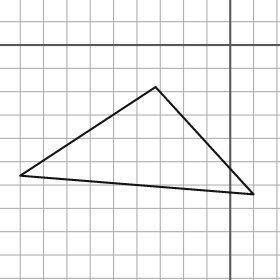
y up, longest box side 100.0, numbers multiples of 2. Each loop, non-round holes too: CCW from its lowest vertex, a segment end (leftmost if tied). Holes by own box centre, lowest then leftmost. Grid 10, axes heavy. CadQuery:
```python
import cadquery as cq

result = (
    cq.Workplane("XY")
    .moveTo(10.0, -64.0)
    .lineTo(-32.0, -18.0)
    .lineTo(-90.0, -56.0)
    .close()
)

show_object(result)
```